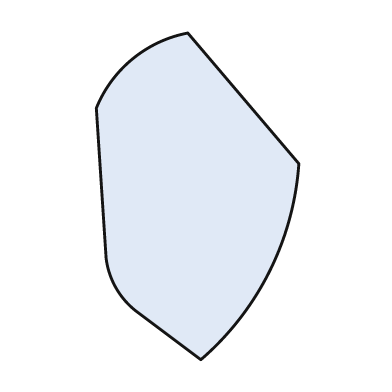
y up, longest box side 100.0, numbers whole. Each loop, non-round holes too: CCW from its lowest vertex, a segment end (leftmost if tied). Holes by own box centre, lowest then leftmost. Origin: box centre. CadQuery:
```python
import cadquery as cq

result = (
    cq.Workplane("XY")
    .moveTo(1.0, -50.0)
    .threePointArc((22.0, -23.0), (31.0, 10.0))
    .lineTo(-3.0, 50.0)
    .threePointArc((-20.0, 42.0), (-31.0, 27.0))
    .lineTo(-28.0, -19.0)
    .threePointArc((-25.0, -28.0), (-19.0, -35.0))
    .close()
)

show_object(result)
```